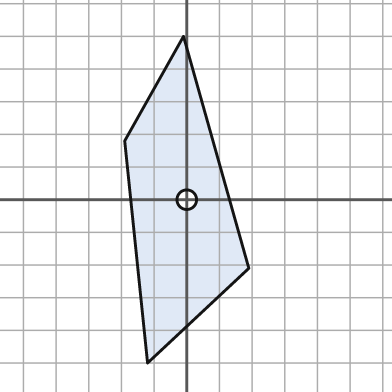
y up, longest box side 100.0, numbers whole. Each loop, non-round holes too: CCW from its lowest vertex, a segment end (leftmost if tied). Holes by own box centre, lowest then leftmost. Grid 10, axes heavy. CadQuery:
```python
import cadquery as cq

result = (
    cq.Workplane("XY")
    .moveTo(-12.0, -50.0)
    .lineTo(19.0, -21.0)
    .lineTo(-1.0, 50.0)
    .lineTo(-19.0, 18.0)
    .close()
    .moveTo(0.0, 0.0)
    .circle(3.0)
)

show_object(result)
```